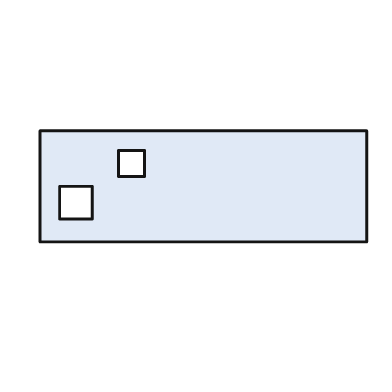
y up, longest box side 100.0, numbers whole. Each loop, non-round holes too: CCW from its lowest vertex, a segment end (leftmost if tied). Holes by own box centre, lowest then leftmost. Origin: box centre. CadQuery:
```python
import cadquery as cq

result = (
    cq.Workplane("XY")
    .moveTo(-50.0, -17.0)
    .lineTo(50.0, -17.0)
    .lineTo(50.0, 17.0)
    .lineTo(-50.0, 17.0)
    .close()
    .moveTo(-44.0, -10.0)
    .lineTo(-34.0, -10.0)
    .lineTo(-34.0, 0.0)
    .lineTo(-44.0, 0.0)
    .close()
    .moveTo(-26.0, 3.0)
    .lineTo(-18.0, 3.0)
    .lineTo(-18.0, 11.0)
    .lineTo(-26.0, 11.0)
    .close()
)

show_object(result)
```